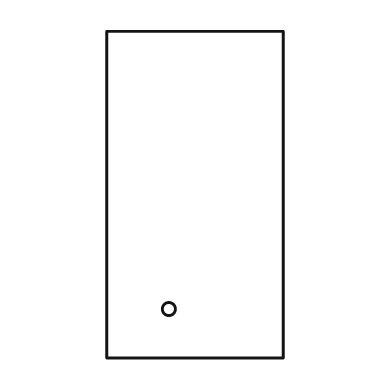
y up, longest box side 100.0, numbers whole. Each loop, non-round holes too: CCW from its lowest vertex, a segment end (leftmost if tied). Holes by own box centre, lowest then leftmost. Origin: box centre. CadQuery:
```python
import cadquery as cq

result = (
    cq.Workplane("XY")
    .moveTo(-27.0, -50.0)
    .lineTo(27.0, -50.0)
    .lineTo(27.0, 50.0)
    .lineTo(-27.0, 50.0)
    .close()
    .moveTo(-8.0, -35.0)
    .circle(2.0)
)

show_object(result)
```